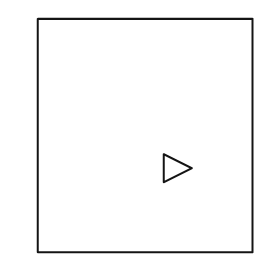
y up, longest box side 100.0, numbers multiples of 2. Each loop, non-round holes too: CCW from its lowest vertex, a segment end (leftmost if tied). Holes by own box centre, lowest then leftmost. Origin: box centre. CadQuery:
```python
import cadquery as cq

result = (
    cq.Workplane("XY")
    .moveTo(-46.0, -50.0)
    .lineTo(46.0, -50.0)
    .lineTo(46.0, 50.0)
    .lineTo(-46.0, 50.0)
    .close()
    .moveTo(8.0, -20.0)
    .lineTo(20.0, -14.0)
    .lineTo(8.0, -8.0)
    .close()
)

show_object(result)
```